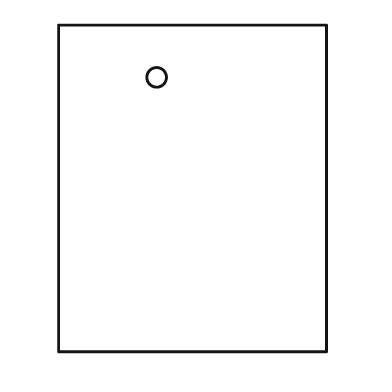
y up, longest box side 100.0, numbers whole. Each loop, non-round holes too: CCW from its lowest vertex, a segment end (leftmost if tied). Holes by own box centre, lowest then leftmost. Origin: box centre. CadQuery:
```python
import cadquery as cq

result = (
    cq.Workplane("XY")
    .moveTo(-41.0, -50.0)
    .lineTo(41.0, -50.0)
    .lineTo(41.0, 50.0)
    .lineTo(-41.0, 50.0)
    .close()
    .moveTo(-11.0, 34.0)
    .circle(3.0)
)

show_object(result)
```